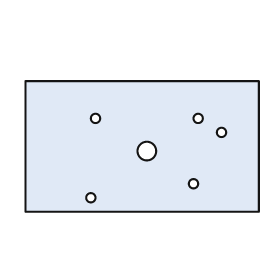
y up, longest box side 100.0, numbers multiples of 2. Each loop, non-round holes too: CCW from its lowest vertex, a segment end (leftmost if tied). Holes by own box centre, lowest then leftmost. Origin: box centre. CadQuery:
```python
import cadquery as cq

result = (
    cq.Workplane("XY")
    .moveTo(-50.0, -28.0)
    .lineTo(50.0, -28.0)
    .lineTo(50.0, 28.0)
    .lineTo(-50.0, 28.0)
    .close()
    .moveTo(-22.0, -22.0)
    .circle(2.0)
    .moveTo(22.0, -16.0)
    .circle(2.0)
    .moveTo(2.0, -2.0)
    .circle(4.0)
    .moveTo(34.0, 6.0)
    .circle(2.0)
    .moveTo(-20.0, 12.0)
    .circle(2.0)
    .moveTo(24.0, 12.0)
    .circle(2.0)
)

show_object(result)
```